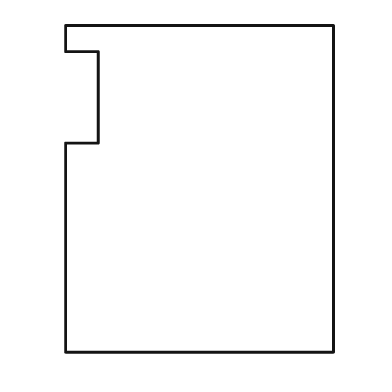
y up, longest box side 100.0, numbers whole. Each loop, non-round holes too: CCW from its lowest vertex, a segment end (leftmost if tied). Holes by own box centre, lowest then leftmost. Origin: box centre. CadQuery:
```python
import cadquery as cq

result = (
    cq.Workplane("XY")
    .moveTo(-41.0, -50.0)
    .lineTo(41.0, -50.0)
    .lineTo(41.0, 50.0)
    .lineTo(-41.0, 50.0)
    .lineTo(-41.0, 42.0)
    .lineTo(-31.0, 42.0)
    .lineTo(-31.0, 14.0)
    .lineTo(-41.0, 14.0)
    .close()
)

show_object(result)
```